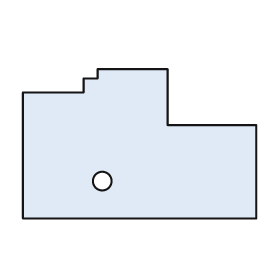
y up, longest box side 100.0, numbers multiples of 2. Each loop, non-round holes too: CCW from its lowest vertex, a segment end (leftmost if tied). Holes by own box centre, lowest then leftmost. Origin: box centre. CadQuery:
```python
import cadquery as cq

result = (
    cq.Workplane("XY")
    .moveTo(-50.0, -32.0)
    .lineTo(50.0, -32.0)
    .lineTo(50.0, 8.0)
    .lineTo(12.0, 8.0)
    .lineTo(12.0, 32.0)
    .lineTo(-18.0, 32.0)
    .lineTo(-18.0, 28.0)
    .lineTo(-24.0, 28.0)
    .lineTo(-24.0, 22.0)
    .lineTo(-50.0, 22.0)
    .close()
    .moveTo(-16.0, -16.0)
    .circle(4.0)
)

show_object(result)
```